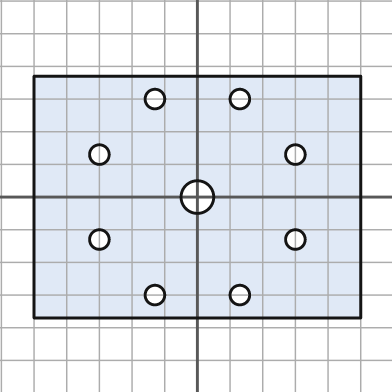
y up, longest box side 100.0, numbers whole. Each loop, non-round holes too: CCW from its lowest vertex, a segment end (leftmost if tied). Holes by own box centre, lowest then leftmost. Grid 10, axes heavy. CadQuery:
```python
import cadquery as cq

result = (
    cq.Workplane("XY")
    .moveTo(-50.0, -37.0)
    .lineTo(50.0, -37.0)
    .lineTo(50.0, 37.0)
    .lineTo(-50.0, 37.0)
    .close()
    .moveTo(-13.0, -30.0)
    .circle(3.0)
    .moveTo(13.0, -30.0)
    .circle(3.0)
    .moveTo(-30.0, -13.0)
    .circle(3.0)
    .moveTo(30.0, -13.0)
    .circle(3.0)
    .moveTo(0.0, 0.0)
    .circle(5.0)
    .moveTo(-30.0, 13.0)
    .circle(3.0)
    .moveTo(30.0, 13.0)
    .circle(3.0)
    .moveTo(-13.0, 30.0)
    .circle(3.0)
    .moveTo(13.0, 30.0)
    .circle(3.0)
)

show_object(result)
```